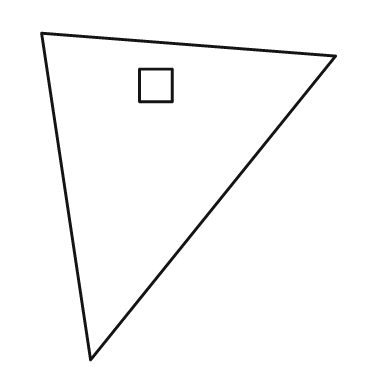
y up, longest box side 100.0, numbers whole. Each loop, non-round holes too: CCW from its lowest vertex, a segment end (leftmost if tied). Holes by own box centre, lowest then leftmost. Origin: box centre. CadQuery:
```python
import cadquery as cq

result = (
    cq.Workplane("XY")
    .moveTo(-30.0, -50.0)
    .lineTo(45.0, 43.0)
    .lineTo(-45.0, 50.0)
    .close()
    .moveTo(-15.0, 29.0)
    .lineTo(-5.0, 29.0)
    .lineTo(-5.0, 39.0)
    .lineTo(-15.0, 39.0)
    .close()
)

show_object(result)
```